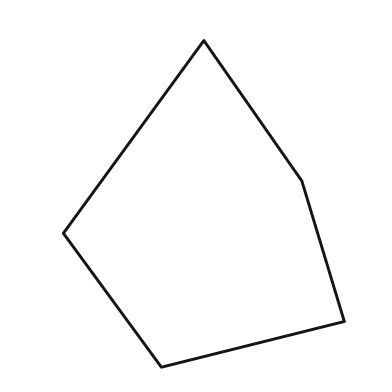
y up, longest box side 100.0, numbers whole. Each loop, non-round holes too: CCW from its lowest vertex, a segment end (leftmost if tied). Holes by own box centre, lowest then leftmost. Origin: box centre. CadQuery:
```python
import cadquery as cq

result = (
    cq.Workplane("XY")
    .moveTo(-13.0, -50.0)
    .lineTo(43.0, -36.0)
    .lineTo(30.0, 7.0)
    .lineTo(0.0, 50.0)
    .lineTo(-43.0, -9.0)
    .close()
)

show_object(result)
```